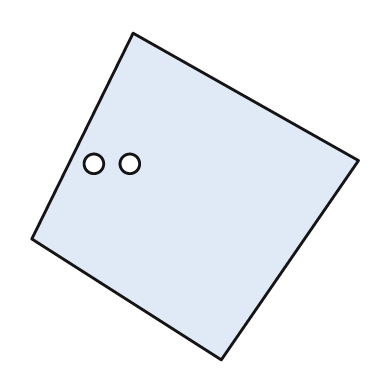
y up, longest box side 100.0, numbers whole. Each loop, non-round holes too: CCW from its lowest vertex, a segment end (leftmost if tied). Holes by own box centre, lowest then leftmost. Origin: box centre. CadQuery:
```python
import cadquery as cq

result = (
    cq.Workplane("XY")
    .moveTo(8.0, -50.0)
    .lineTo(50.0, 11.0)
    .lineTo(-19.0, 50.0)
    .lineTo(-50.0, -13.0)
    .close()
    .moveTo(-31.0, 10.0)
    .circle(3.0)
    .moveTo(-20.0, 10.0)
    .circle(3.0)
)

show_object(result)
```